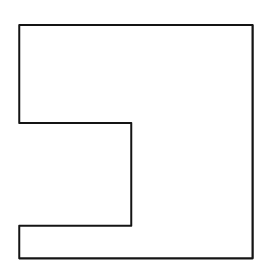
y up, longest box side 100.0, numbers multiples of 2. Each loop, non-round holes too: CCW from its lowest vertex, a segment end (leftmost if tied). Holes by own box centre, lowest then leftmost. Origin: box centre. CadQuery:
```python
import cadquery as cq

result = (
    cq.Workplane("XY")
    .moveTo(-50.0, -50.0)
    .lineTo(50.0, -50.0)
    .lineTo(50.0, 50.0)
    .lineTo(-50.0, 50.0)
    .lineTo(-50.0, 8.0)
    .lineTo(-2.0, 8.0)
    .lineTo(-2.0, -36.0)
    .lineTo(-50.0, -36.0)
    .close()
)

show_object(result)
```